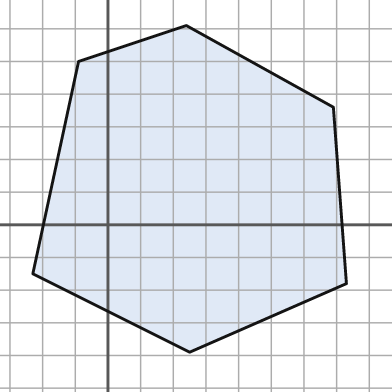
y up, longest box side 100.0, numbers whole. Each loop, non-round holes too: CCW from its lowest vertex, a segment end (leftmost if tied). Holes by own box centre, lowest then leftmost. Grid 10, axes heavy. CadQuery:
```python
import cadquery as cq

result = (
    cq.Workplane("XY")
    .moveTo(25.0, -39.0)
    .lineTo(73.0, -18.0)
    .lineTo(69.0, 36.0)
    .lineTo(24.0, 61.0)
    .lineTo(-9.0, 50.0)
    .lineTo(-23.0, -15.0)
    .close()
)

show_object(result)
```